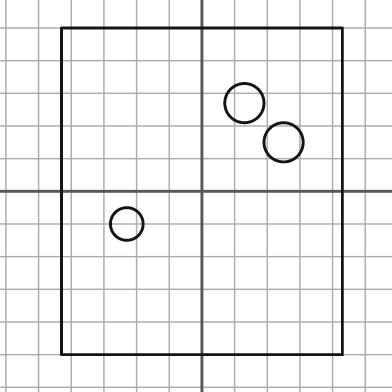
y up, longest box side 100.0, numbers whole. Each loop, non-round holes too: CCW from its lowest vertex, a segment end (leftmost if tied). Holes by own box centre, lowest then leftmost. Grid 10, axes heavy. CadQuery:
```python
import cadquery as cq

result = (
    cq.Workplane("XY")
    .moveTo(-43.0, -50.0)
    .lineTo(43.0, -50.0)
    .lineTo(43.0, 50.0)
    .lineTo(-43.0, 50.0)
    .close()
    .moveTo(-23.0, -10.0)
    .circle(5.0)
    .moveTo(25.0, 15.0)
    .circle(6.0)
    .moveTo(13.0, 27.0)
    .circle(6.0)
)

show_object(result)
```